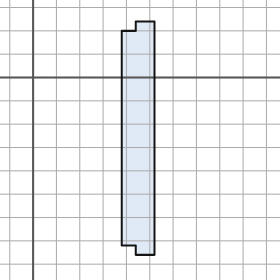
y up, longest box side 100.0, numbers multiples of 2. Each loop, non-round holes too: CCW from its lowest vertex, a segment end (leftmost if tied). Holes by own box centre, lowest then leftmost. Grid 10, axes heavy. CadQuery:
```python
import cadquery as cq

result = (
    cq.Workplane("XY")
    .moveTo(44.0, -76.0)
    .lineTo(52.0, -76.0)
    .lineTo(52.0, 24.0)
    .lineTo(44.0, 24.0)
    .lineTo(44.0, 20.0)
    .lineTo(38.0, 20.0)
    .lineTo(38.0, -72.0)
    .lineTo(44.0, -72.0)
    .close()
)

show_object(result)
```